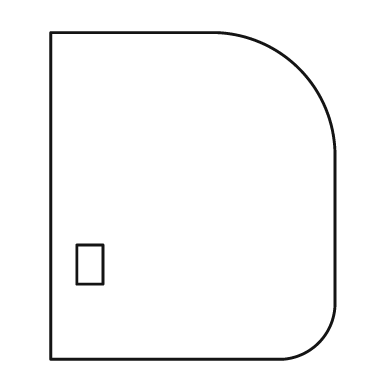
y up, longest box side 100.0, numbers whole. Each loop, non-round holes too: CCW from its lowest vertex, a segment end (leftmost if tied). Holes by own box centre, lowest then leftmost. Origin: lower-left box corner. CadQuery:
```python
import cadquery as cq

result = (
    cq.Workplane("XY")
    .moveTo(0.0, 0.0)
    .lineTo(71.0, 0.0)
    .threePointArc((82.0, 5.0), (87.0, 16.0))
    .lineTo(87.0, 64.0)
    .threePointArc((76.0, 89.0), (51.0, 100.0))
    .lineTo(0.0, 100.0)
    .close()
    .moveTo(8.0, 23.0)
    .lineTo(16.0, 23.0)
    .lineTo(16.0, 35.0)
    .lineTo(8.0, 35.0)
    .close()
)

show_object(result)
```